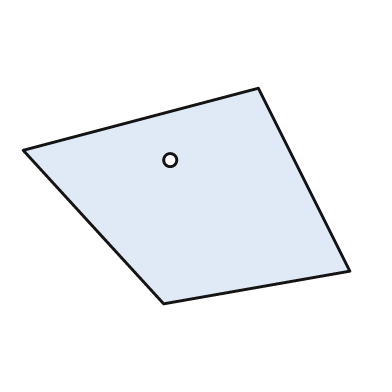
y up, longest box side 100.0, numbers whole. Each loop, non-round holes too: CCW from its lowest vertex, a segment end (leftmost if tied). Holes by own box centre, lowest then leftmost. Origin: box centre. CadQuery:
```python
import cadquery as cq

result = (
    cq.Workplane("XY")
    .moveTo(-7.0, -33.0)
    .lineTo(50.0, -23.0)
    .lineTo(22.0, 33.0)
    .lineTo(-50.0, 14.0)
    .close()
    .moveTo(-5.0, 11.0)
    .circle(2.0)
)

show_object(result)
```